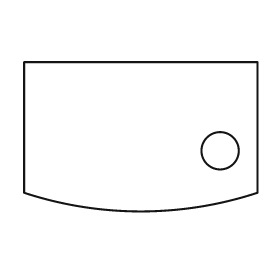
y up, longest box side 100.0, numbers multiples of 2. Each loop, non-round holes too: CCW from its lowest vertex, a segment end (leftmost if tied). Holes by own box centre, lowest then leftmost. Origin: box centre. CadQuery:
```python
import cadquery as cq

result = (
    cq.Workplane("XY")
    .moveTo(-50.0, -24.0)
    .threePointArc((0.0, -32.0), (50.0, -24.0))
    .lineTo(50.0, 32.0)
    .lineTo(-50.0, 32.0)
    .close()
    .moveTo(34.0, -6.0)
    .circle(8.0)
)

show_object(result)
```